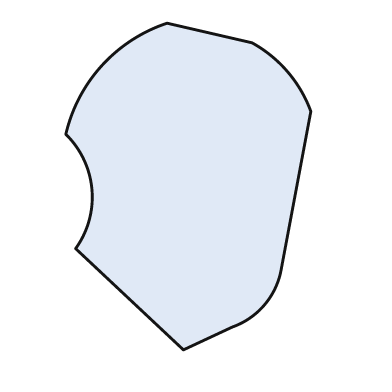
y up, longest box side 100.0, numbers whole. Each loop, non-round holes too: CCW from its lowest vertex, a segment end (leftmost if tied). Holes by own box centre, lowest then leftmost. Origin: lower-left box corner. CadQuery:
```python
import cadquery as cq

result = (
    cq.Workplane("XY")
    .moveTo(36.0, 0.0)
    .lineTo(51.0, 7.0)
    .threePointArc((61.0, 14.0), (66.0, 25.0))
    .lineTo(75.0, 73.0)
    .threePointArc((68.0, 85.0), (57.0, 94.0))
    .lineTo(31.0, 100.0)
    .threePointArc((11.0, 87.0), (0.0, 66.0))
    .threePointArc((8.0, 49.0), (3.0, 31.0))
    .close()
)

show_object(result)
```